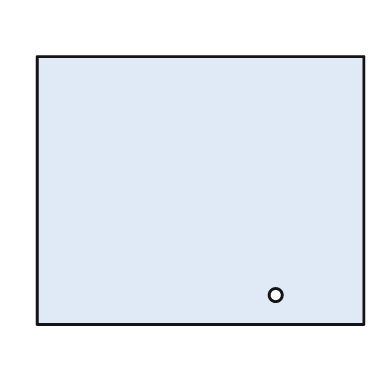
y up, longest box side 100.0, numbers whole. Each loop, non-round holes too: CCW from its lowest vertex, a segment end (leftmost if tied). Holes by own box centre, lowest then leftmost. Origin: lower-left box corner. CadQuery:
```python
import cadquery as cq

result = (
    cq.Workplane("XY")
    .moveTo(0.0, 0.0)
    .lineTo(100.0, 0.0)
    .lineTo(100.0, 82.0)
    .lineTo(0.0, 82.0)
    .close()
    .moveTo(73.0, 9.0)
    .circle(2.0)
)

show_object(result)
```